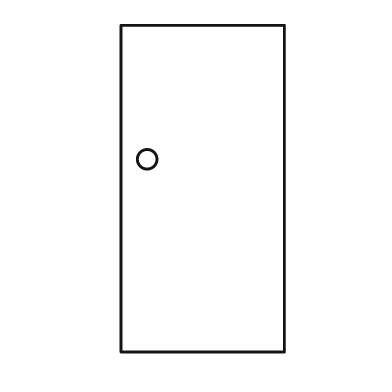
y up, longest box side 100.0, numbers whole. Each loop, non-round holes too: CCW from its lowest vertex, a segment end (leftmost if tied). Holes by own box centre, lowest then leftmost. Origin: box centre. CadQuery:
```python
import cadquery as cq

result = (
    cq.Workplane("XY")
    .moveTo(-25.0, -50.0)
    .lineTo(25.0, -50.0)
    .lineTo(25.0, 50.0)
    .lineTo(-25.0, 50.0)
    .close()
    .moveTo(-17.0, 9.0)
    .circle(3.0)
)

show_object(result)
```